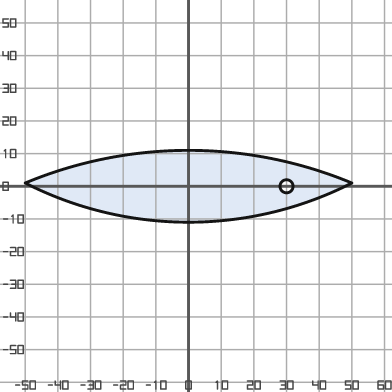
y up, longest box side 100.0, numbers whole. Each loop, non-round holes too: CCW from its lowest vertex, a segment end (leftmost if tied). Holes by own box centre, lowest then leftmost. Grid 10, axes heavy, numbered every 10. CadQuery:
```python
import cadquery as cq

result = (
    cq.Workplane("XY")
    .moveTo(-50.0, 1.0)
    .threePointArc((0.0, -11.0), (50.0, 1.0))
    .threePointArc((0.0, 11.0), (-50.0, 1.0))
    .close()
    .moveTo(30.0, 0.0)
    .circle(2.0)
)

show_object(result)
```